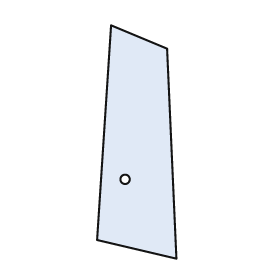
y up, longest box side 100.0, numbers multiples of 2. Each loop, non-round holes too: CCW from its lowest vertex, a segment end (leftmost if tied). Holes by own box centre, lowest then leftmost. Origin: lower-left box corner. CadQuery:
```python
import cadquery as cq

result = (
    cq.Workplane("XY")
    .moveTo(34.0, 0.0)
    .lineTo(30.0, 90.0)
    .lineTo(6.0, 100.0)
    .lineTo(0.0, 8.0)
    .close()
    .moveTo(12.0, 34.0)
    .circle(2.0)
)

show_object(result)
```